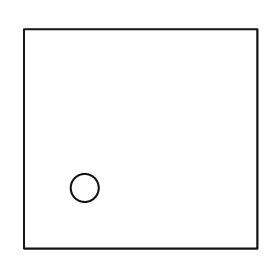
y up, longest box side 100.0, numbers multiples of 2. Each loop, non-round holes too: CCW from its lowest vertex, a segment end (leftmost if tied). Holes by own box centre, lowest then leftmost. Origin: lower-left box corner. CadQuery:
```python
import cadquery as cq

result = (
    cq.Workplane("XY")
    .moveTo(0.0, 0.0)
    .lineTo(100.0, 0.0)
    .lineTo(100.0, 94.0)
    .lineTo(0.0, 94.0)
    .close()
    .moveTo(26.0, 26.0)
    .circle(6.0)
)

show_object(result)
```